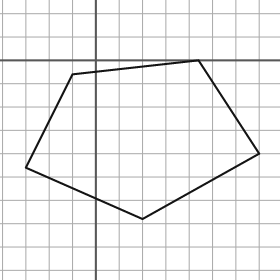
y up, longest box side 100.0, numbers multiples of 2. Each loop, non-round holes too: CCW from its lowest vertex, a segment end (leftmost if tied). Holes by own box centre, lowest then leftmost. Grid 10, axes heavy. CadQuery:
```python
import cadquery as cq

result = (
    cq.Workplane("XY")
    .moveTo(20.0, -68.0)
    .lineTo(70.0, -40.0)
    .lineTo(44.0, 0.0)
    .lineTo(-10.0, -6.0)
    .lineTo(-30.0, -46.0)
    .close()
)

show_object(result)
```